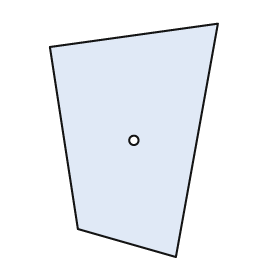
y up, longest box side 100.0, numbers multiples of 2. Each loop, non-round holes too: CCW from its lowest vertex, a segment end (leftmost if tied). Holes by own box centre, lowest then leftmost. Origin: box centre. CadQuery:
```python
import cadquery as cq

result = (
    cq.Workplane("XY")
    .moveTo(18.0, -50.0)
    .lineTo(36.0, 50.0)
    .lineTo(-36.0, 40.0)
    .lineTo(-24.0, -38.0)
    .close()
    .moveTo(0.0, 0.0)
    .circle(2.0)
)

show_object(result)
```